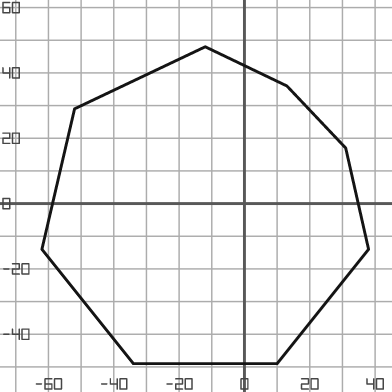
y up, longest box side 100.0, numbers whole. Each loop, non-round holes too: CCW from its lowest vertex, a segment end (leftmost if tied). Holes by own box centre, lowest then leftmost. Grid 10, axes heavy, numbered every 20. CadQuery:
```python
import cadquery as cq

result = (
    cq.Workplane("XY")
    .moveTo(-34.0, -49.0)
    .lineTo(10.0, -49.0)
    .lineTo(38.0, -14.0)
    .lineTo(31.0, 17.0)
    .lineTo(13.0, 36.0)
    .lineTo(-12.0, 48.0)
    .lineTo(-52.0, 29.0)
    .lineTo(-62.0, -14.0)
    .close()
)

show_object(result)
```